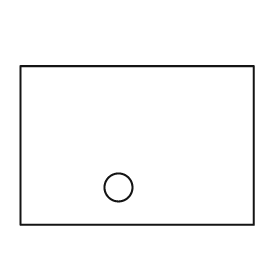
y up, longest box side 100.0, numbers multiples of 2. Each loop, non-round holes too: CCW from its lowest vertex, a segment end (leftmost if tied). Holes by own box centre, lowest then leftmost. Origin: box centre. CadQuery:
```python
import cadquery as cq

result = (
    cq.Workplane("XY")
    .moveTo(-50.0, -34.0)
    .lineTo(50.0, -34.0)
    .lineTo(50.0, 34.0)
    .lineTo(-50.0, 34.0)
    .close()
    .moveTo(-8.0, -18.0)
    .circle(6.0)
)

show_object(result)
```